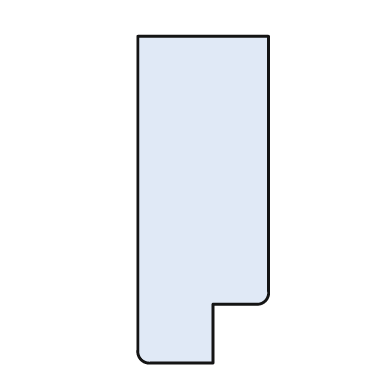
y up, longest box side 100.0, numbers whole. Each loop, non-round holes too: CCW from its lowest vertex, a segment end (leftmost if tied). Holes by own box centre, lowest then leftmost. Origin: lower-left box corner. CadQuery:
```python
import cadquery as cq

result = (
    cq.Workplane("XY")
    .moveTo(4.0, 0.0)
    .lineTo(23.0, 0.0)
    .lineTo(23.0, 18.0)
    .lineTo(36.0, 18.0)
    .threePointArc((39.0, 19.0), (40.0, 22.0))
    .lineTo(40.0, 100.0)
    .lineTo(0.0, 100.0)
    .lineTo(0.0, 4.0)
    .threePointArc((1.0, 1.0), (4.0, 0.0))
    .close()
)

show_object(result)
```